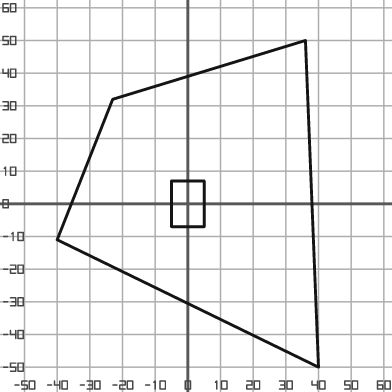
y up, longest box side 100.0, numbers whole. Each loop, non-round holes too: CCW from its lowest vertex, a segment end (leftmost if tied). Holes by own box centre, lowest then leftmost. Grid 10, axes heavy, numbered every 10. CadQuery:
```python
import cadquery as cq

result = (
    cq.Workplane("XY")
    .moveTo(40.0, -50.0)
    .lineTo(36.0, 50.0)
    .lineTo(-23.0, 32.0)
    .lineTo(-40.0, -11.0)
    .close()
    .moveTo(-5.0, -7.0)
    .lineTo(5.0, -7.0)
    .lineTo(5.0, 7.0)
    .lineTo(-5.0, 7.0)
    .close()
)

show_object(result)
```